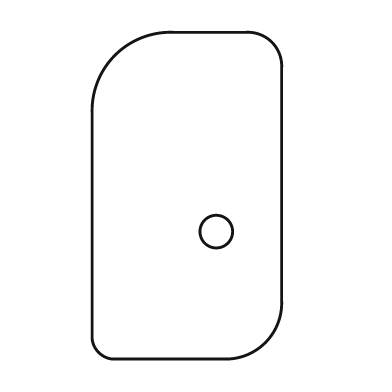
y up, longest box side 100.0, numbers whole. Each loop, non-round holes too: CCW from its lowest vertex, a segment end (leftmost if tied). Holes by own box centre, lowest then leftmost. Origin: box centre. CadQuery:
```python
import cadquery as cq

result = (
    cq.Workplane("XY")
    .moveTo(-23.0, -50.0)
    .lineTo(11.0, -50.0)
    .threePointArc((24.0, -45.0), (29.0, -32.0))
    .lineTo(29.0, 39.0)
    .threePointArc((26.0, 47.0), (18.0, 50.0))
    .lineTo(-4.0, 50.0)
    .threePointArc((-22.0, 43.0), (-29.0, 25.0))
    .lineTo(-29.0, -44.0)
    .threePointArc((-27.0, -48.0), (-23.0, -50.0))
    .close()
    .moveTo(9.0, -11.0)
    .circle(5.0)
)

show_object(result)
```